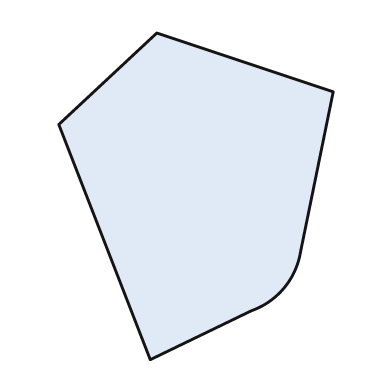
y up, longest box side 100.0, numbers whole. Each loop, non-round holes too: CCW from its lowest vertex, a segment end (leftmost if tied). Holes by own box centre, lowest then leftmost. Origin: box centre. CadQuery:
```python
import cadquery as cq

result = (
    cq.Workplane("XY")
    .moveTo(-14.0, -50.0)
    .lineTo(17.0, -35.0)
    .threePointArc((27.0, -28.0), (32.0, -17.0))
    .lineTo(42.0, 32.0)
    .lineTo(-12.0, 50.0)
    .lineTo(-42.0, 22.0)
    .close()
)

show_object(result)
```